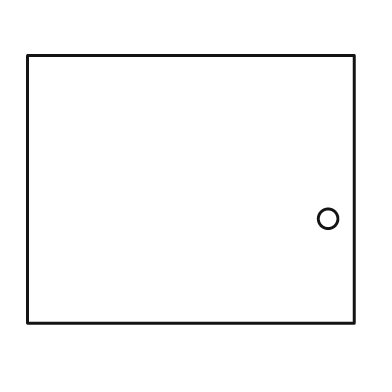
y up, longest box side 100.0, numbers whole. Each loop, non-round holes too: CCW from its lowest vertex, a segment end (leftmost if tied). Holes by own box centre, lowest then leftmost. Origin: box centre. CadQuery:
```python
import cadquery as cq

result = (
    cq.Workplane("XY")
    .moveTo(-50.0, -41.0)
    .lineTo(50.0, -41.0)
    .lineTo(50.0, 41.0)
    .lineTo(-50.0, 41.0)
    .close()
    .moveTo(42.0, -9.0)
    .circle(3.0)
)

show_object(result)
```